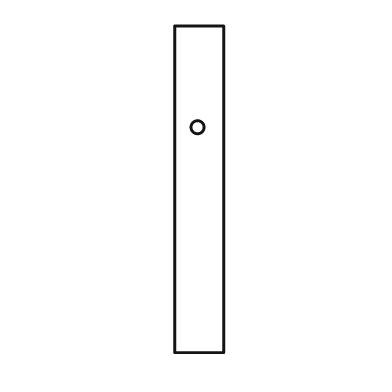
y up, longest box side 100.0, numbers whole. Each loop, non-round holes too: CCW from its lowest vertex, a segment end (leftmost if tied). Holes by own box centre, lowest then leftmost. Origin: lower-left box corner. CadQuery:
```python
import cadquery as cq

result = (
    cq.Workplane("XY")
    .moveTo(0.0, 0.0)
    .lineTo(15.0, 0.0)
    .lineTo(15.0, 100.0)
    .lineTo(0.0, 100.0)
    .close()
    .moveTo(7.0, 69.0)
    .circle(2.0)
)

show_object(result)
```